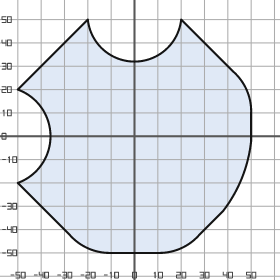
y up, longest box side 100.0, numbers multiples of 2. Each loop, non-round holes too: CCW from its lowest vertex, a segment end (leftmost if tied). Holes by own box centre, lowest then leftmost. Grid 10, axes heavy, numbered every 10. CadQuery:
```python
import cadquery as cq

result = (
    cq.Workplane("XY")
    .moveTo(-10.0, -50.0)
    .lineTo(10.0, -50.0)
    .threePointArc((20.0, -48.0), (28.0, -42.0))
    .lineTo(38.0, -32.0)
    .threePointArc((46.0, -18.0), (50.0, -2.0))
    .lineTo(50.0, 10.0)
    .threePointArc((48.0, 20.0), (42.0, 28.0))
    .lineTo(20.0, 50.0)
    .threePointArc((0.0, 32.0), (-20.0, 50.0))
    .lineTo(-50.0, 20.0)
    .threePointArc((-36.0, 0.0), (-50.0, -20.0))
    .lineTo(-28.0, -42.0)
    .threePointArc((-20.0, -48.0), (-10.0, -50.0))
    .close()
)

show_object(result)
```